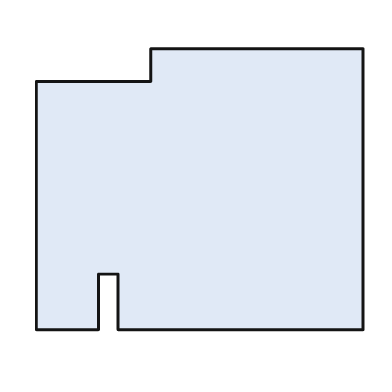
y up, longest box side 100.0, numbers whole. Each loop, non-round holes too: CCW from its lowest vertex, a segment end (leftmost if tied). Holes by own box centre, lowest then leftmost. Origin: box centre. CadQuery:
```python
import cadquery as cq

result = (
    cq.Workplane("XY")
    .moveTo(-50.0, -43.0)
    .lineTo(-31.0, -43.0)
    .lineTo(-31.0, -26.0)
    .lineTo(-25.0, -26.0)
    .lineTo(-25.0, -43.0)
    .lineTo(50.0, -43.0)
    .lineTo(50.0, 43.0)
    .lineTo(-15.0, 43.0)
    .lineTo(-15.0, 33.0)
    .lineTo(-50.0, 33.0)
    .close()
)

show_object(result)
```